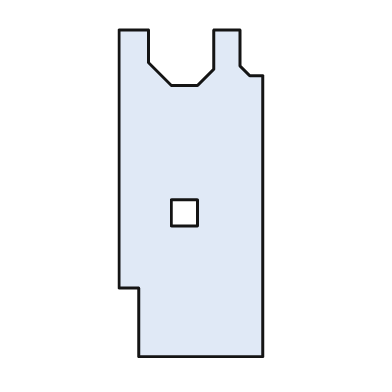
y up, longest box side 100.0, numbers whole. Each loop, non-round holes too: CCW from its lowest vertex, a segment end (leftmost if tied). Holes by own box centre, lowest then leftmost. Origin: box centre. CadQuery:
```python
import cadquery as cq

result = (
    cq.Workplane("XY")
    .moveTo(-16.0, -50.0)
    .lineTo(22.0, -50.0)
    .lineTo(22.0, 36.0)
    .lineTo(18.0, 36.0)
    .lineTo(15.0, 39.0)
    .lineTo(15.0, 50.0)
    .lineTo(7.0, 50.0)
    .lineTo(7.0, 38.0)
    .lineTo(2.0, 33.0)
    .lineTo(-6.0, 33.0)
    .lineTo(-13.0, 40.0)
    .lineTo(-13.0, 50.0)
    .lineTo(-22.0, 50.0)
    .lineTo(-22.0, -29.0)
    .lineTo(-16.0, -29.0)
    .close()
    .moveTo(-6.0, -10.0)
    .lineTo(2.0, -10.0)
    .lineTo(2.0, -2.0)
    .lineTo(-6.0, -2.0)
    .close()
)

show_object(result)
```